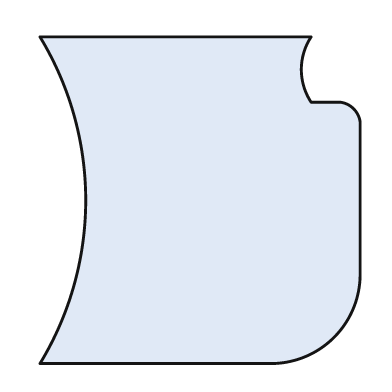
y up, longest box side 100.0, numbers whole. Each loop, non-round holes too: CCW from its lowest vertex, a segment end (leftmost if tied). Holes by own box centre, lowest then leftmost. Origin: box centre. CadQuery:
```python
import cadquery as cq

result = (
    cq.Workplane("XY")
    .moveTo(-49.0, -50.0)
    .lineTo(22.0, -50.0)
    .threePointArc((41.0, -42.0), (49.0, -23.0))
    .lineTo(49.0, 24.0)
    .threePointArc((47.0, 28.0), (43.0, 30.0))
    .lineTo(34.0, 30.0)
    .threePointArc((31.0, 40.0), (34.0, 50.0))
    .lineTo(-49.0, 50.0)
    .threePointArc((-35.0, 0.0), (-49.0, -50.0))
    .close()
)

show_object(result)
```